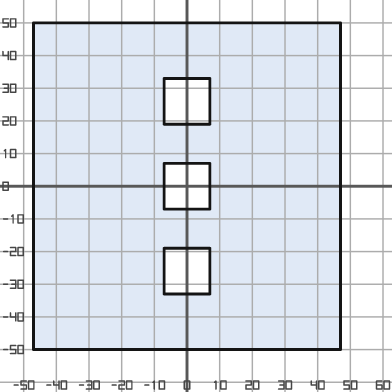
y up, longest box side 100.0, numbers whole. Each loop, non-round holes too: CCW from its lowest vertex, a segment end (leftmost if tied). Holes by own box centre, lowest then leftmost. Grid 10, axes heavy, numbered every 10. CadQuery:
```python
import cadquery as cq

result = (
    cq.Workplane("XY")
    .moveTo(-47.0, -50.0)
    .lineTo(47.0, -50.0)
    .lineTo(47.0, 50.0)
    .lineTo(-47.0, 50.0)
    .close()
    .moveTo(-7.0, -33.0)
    .lineTo(7.0, -33.0)
    .lineTo(7.0, -19.0)
    .lineTo(-7.0, -19.0)
    .close()
    .moveTo(-7.0, -7.0)
    .lineTo(7.0, -7.0)
    .lineTo(7.0, 7.0)
    .lineTo(-7.0, 7.0)
    .close()
    .moveTo(-7.0, 19.0)
    .lineTo(7.0, 19.0)
    .lineTo(7.0, 33.0)
    .lineTo(-7.0, 33.0)
    .close()
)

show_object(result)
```